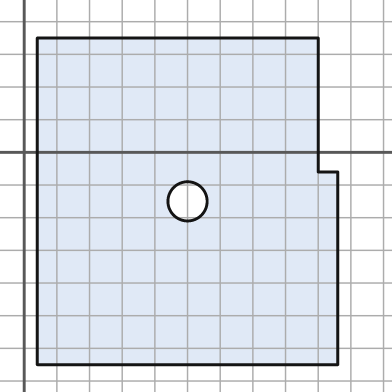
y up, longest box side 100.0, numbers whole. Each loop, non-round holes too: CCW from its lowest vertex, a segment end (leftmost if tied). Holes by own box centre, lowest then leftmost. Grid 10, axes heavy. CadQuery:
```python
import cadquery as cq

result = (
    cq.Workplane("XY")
    .moveTo(4.0, -65.0)
    .lineTo(96.0, -65.0)
    .lineTo(96.0, -6.0)
    .lineTo(90.0, -6.0)
    .lineTo(90.0, 35.0)
    .lineTo(4.0, 35.0)
    .close()
    .moveTo(50.0, -15.0)
    .circle(6.0)
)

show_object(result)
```